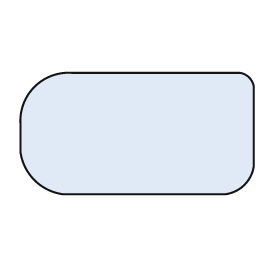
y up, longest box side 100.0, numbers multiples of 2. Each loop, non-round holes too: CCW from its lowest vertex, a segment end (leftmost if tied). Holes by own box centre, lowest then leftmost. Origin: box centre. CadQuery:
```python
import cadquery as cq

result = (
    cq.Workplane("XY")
    .moveTo(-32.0, -26.0)
    .lineTo(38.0, -26.0)
    .threePointArc((46.0, -22.0), (50.0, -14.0))
    .lineTo(50.0, 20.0)
    .threePointArc((48.0, 24.0), (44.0, 26.0))
    .lineTo(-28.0, 26.0)
    .threePointArc((-44.0, 20.0), (-50.0, 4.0))
    .lineTo(-50.0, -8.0)
    .threePointArc((-44.0, -20.0), (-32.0, -26.0))
    .close()
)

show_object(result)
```